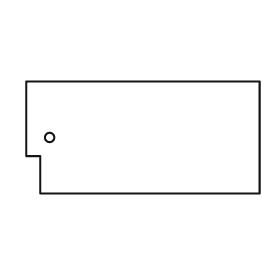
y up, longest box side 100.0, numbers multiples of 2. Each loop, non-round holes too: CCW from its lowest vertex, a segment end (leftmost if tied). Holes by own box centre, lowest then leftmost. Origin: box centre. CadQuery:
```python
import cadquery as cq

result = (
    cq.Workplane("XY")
    .moveTo(-44.0, -24.0)
    .lineTo(50.0, -24.0)
    .lineTo(50.0, 24.0)
    .lineTo(-50.0, 24.0)
    .lineTo(-50.0, -8.0)
    .lineTo(-44.0, -8.0)
    .close()
    .moveTo(-40.0, 0.0)
    .circle(2.0)
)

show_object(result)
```